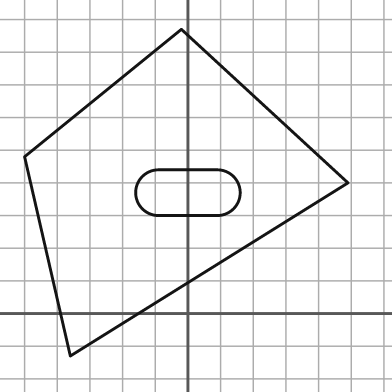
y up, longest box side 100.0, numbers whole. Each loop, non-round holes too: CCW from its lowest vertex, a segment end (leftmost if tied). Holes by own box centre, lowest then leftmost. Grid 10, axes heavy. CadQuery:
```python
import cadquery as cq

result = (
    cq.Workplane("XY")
    .moveTo(-36.0, -13.0)
    .lineTo(49.0, 40.0)
    .lineTo(-2.0, 87.0)
    .lineTo(-50.0, 48.0)
    .close()
    .moveTo(-9.0, 30.0)
    .lineTo(9.0, 30.0)
    .threePointArc((16.0, 37.0), (9.0, 44.0))
    .lineTo(-9.0, 44.0)
    .threePointArc((-16.0, 37.0), (-9.0, 30.0))
    .close()
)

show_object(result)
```